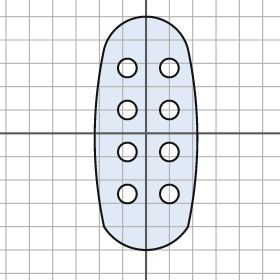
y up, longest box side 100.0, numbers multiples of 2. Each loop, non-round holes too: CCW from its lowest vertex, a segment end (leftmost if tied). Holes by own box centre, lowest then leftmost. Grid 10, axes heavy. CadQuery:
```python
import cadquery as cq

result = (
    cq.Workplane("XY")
    .moveTo(-18.0, -40.0)
    .threePointArc((0.0, -50.0), (18.0, -40.0))
    .threePointArc((22.0, -2.0), (18.0, 36.0))
    .threePointArc((0.0, 50.0), (-18.0, 36.0))
    .threePointArc((-22.0, -2.0), (-18.0, -40.0))
    .close()
    .moveTo(-8.0, -26.0)
    .circle(4.0)
    .moveTo(10.0, -26.0)
    .circle(4.0)
    .moveTo(-8.0, -8.0)
    .circle(4.0)
    .moveTo(10.0, -8.0)
    .circle(4.0)
    .moveTo(-8.0, 10.0)
    .circle(4.0)
    .moveTo(10.0, 10.0)
    .circle(4.0)
    .moveTo(-8.0, 28.0)
    .circle(4.0)
    .moveTo(10.0, 28.0)
    .circle(4.0)
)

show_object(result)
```